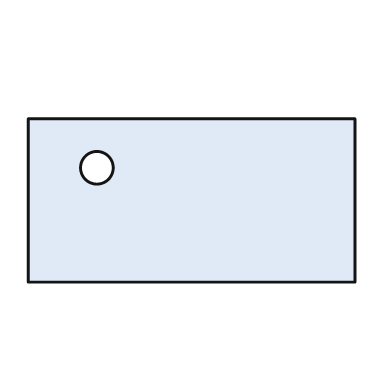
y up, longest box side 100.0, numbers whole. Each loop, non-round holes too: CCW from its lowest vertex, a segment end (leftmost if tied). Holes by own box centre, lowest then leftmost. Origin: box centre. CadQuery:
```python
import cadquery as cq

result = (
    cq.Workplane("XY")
    .moveTo(-50.0, -25.0)
    .lineTo(50.0, -25.0)
    .lineTo(50.0, 25.0)
    .lineTo(-50.0, 25.0)
    .close()
    .moveTo(-29.0, 10.0)
    .circle(5.0)
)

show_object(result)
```